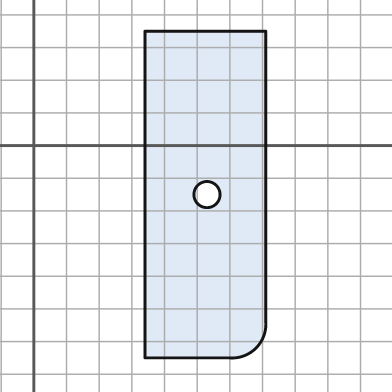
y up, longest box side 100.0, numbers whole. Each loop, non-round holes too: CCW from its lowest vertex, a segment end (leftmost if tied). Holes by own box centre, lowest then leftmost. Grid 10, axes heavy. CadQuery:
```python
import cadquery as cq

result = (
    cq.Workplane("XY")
    .moveTo(34.0, -65.0)
    .lineTo(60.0, -65.0)
    .threePointArc((68.0, -62.0), (71.0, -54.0))
    .lineTo(71.0, 35.0)
    .lineTo(34.0, 35.0)
    .close()
    .moveTo(53.0, -15.0)
    .circle(4.0)
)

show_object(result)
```